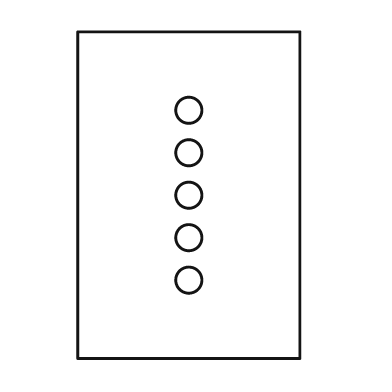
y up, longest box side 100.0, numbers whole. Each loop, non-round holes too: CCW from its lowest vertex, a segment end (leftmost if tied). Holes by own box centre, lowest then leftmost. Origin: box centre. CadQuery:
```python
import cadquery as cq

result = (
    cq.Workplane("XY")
    .moveTo(-34.0, -50.0)
    .lineTo(34.0, -50.0)
    .lineTo(34.0, 50.0)
    .lineTo(-34.0, 50.0)
    .close()
    .moveTo(0.0, -26.0)
    .circle(4.0)
    .moveTo(0.0, -13.0)
    .circle(4.0)
    .moveTo(0.0, 0.0)
    .circle(4.0)
    .moveTo(0.0, 13.0)
    .circle(4.0)
    .moveTo(0.0, 26.0)
    .circle(4.0)
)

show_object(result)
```